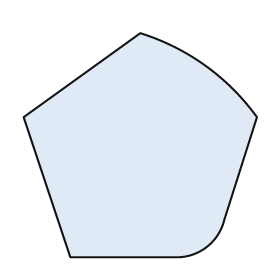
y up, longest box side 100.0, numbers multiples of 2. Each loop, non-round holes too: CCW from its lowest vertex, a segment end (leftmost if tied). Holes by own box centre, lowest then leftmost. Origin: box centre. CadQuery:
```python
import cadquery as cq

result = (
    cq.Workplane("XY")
    .moveTo(-30.0, -48.0)
    .lineTo(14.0, -48.0)
    .threePointArc((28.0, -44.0), (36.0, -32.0))
    .lineTo(50.0, 12.0)
    .threePointArc((28.0, 34.0), (0.0, 48.0))
    .lineTo(-50.0, 12.0)
    .close()
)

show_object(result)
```